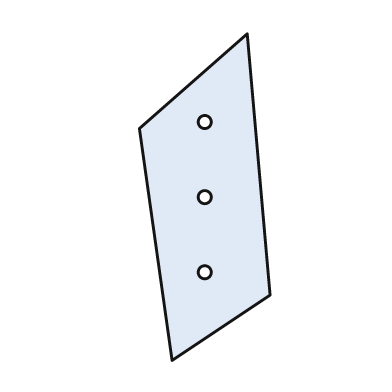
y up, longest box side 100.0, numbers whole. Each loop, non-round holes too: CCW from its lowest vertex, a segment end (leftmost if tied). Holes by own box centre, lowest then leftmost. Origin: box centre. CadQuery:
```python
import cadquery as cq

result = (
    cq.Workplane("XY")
    .moveTo(-10.0, -50.0)
    .lineTo(20.0, -30.0)
    .lineTo(13.0, 50.0)
    .lineTo(-20.0, 21.0)
    .close()
    .moveTo(0.0, -23.0)
    .circle(2.0)
    .moveTo(0.0, 0.0)
    .circle(2.0)
    .moveTo(0.0, 23.0)
    .circle(2.0)
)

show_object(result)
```